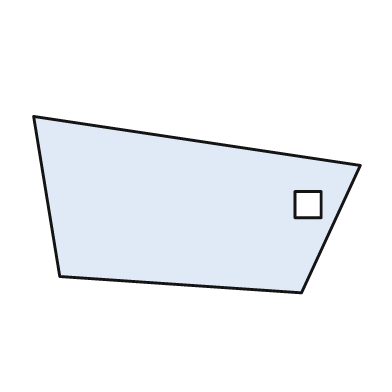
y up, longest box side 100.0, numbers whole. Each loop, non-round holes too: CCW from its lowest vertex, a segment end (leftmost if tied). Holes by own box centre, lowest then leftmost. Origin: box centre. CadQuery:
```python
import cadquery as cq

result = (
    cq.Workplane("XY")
    .moveTo(32.0, -27.0)
    .lineTo(50.0, 12.0)
    .lineTo(-50.0, 27.0)
    .lineTo(-42.0, -22.0)
    .close()
    .moveTo(30.0, -4.0)
    .lineTo(38.0, -4.0)
    .lineTo(38.0, 4.0)
    .lineTo(30.0, 4.0)
    .close()
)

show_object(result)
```